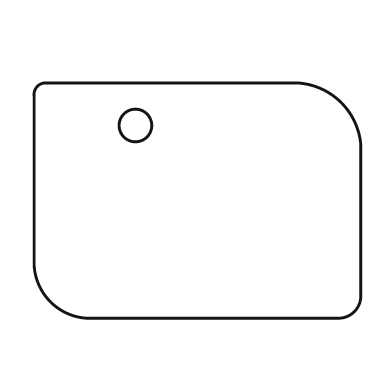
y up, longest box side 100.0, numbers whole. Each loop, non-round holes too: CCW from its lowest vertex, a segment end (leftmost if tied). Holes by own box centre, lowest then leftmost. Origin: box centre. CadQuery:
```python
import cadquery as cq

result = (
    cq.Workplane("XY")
    .moveTo(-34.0, -36.0)
    .lineTo(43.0, -36.0)
    .threePointArc((48.0, -34.0), (50.0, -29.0))
    .lineTo(50.0, 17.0)
    .threePointArc((44.0, 30.0), (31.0, 36.0))
    .lineTo(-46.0, 36.0)
    .threePointArc((-49.0, 35.0), (-50.0, 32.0))
    .lineTo(-50.0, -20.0)
    .threePointArc((-45.0, -31.0), (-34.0, -36.0))
    .close()
    .moveTo(-19.0, 23.0)
    .circle(5.0)
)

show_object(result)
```